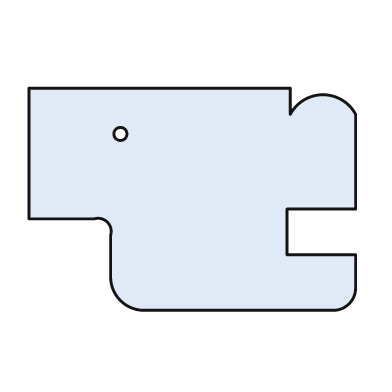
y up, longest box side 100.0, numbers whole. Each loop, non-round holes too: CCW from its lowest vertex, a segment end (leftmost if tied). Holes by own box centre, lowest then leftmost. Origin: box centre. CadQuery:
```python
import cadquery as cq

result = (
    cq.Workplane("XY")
    .moveTo(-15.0, -34.0)
    .lineTo(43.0, -34.0)
    .threePointArc((48.0, -32.0), (50.0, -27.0))
    .lineTo(50.0, -17.0)
    .lineTo(29.0, -17.0)
    .lineTo(29.0, -3.0)
    .lineTo(50.0, -3.0)
    .lineTo(50.0, 26.0)
    .threePointArc((40.0, 32.0), (30.0, 26.0))
    .lineTo(30.0, 34.0)
    .lineTo(-50.0, 34.0)
    .lineTo(-50.0, -6.0)
    .lineTo(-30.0, -6.0)
    .threePointArc((-26.0, -7.0), (-25.0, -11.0))
    .lineTo(-25.0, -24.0)
    .threePointArc((-22.0, -31.0), (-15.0, -34.0))
    .close()
    .moveTo(-22.0, 20.0)
    .circle(2.0)
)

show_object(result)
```